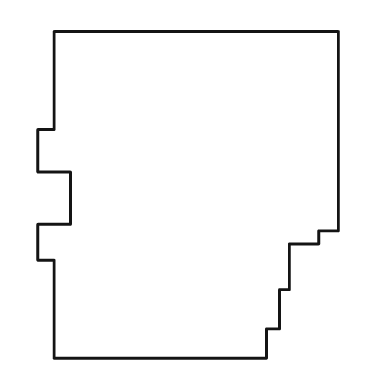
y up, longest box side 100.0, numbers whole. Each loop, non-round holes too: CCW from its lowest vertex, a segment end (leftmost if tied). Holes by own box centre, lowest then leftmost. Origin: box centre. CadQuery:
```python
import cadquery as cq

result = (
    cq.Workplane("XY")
    .moveTo(-41.0, -50.0)
    .lineTo(24.0, -50.0)
    .lineTo(24.0, -41.0)
    .lineTo(28.0, -41.0)
    .lineTo(28.0, -29.0)
    .lineTo(31.0, -29.0)
    .lineTo(31.0, -15.0)
    .lineTo(40.0, -15.0)
    .lineTo(40.0, -11.0)
    .lineTo(46.0, -11.0)
    .lineTo(46.0, 50.0)
    .lineTo(-41.0, 50.0)
    .lineTo(-41.0, 20.0)
    .lineTo(-46.0, 20.0)
    .lineTo(-46.0, 7.0)
    .lineTo(-36.0, 7.0)
    .lineTo(-36.0, -9.0)
    .lineTo(-46.0, -9.0)
    .lineTo(-46.0, -20.0)
    .lineTo(-41.0, -20.0)
    .close()
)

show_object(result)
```